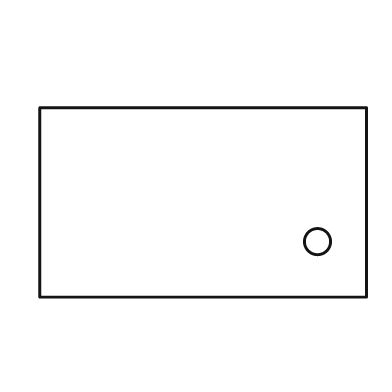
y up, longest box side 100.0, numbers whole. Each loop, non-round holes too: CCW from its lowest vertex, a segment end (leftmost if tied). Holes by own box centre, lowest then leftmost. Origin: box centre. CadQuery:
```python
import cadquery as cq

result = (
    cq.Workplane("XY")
    .moveTo(-50.0, -29.0)
    .lineTo(50.0, -29.0)
    .lineTo(50.0, 29.0)
    .lineTo(-50.0, 29.0)
    .close()
    .moveTo(35.0, -12.0)
    .circle(4.0)
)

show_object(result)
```